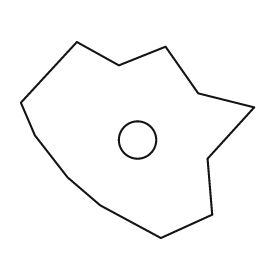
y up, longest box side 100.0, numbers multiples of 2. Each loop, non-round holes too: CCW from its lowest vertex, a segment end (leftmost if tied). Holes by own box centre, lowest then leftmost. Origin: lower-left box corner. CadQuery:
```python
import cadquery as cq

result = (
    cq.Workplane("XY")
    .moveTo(60.0, 0.0)
    .lineTo(82.0, 10.0)
    .lineTo(80.0, 34.0)
    .lineTo(100.0, 56.0)
    .lineTo(76.0, 62.0)
    .lineTo(62.0, 82.0)
    .lineTo(42.0, 74.0)
    .lineTo(24.0, 84.0)
    .lineTo(0.0, 58.0)
    .lineTo(6.0, 44.0)
    .lineTo(20.0, 26.0)
    .lineTo(34.0, 14.0)
    .close()
    .moveTo(50.0, 42.0)
    .circle(8.0)
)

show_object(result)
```